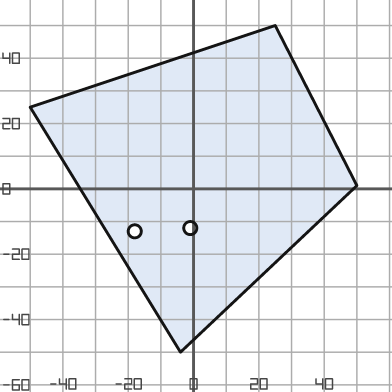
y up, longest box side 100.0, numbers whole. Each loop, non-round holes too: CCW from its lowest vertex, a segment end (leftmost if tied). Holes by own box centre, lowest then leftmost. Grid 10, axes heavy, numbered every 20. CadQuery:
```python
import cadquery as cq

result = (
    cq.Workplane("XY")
    .moveTo(-4.0, -50.0)
    .lineTo(50.0, 1.0)
    .lineTo(25.0, 50.0)
    .lineTo(-50.0, 25.0)
    .close()
    .moveTo(-18.0, -13.0)
    .circle(2.0)
    .moveTo(-1.0, -12.0)
    .circle(2.0)
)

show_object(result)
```